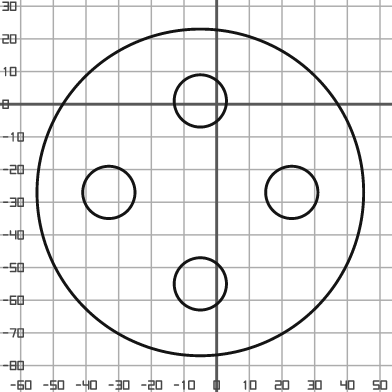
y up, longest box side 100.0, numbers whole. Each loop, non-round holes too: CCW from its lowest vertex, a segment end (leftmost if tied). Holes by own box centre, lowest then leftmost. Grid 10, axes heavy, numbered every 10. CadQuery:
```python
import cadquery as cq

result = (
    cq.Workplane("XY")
    .moveTo(-5.0, -27.0)
    .circle(50.0)
    .moveTo(-5.0, -55.0)
    .circle(8.0)
    .moveTo(-33.0, -27.0)
    .circle(8.0)
    .moveTo(23.0, -27.0)
    .circle(8.0)
    .moveTo(-5.0, 1.0)
    .circle(8.0)
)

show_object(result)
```